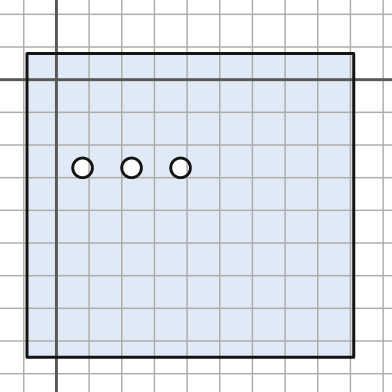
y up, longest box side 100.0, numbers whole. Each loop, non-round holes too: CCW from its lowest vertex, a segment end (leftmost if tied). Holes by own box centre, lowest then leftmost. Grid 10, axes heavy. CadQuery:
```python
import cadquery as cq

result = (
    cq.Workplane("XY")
    .moveTo(-9.0, -85.0)
    .lineTo(91.0, -85.0)
    .lineTo(91.0, 8.0)
    .lineTo(-9.0, 8.0)
    .close()
    .moveTo(8.0, -27.0)
    .circle(3.0)
    .moveTo(23.0, -27.0)
    .circle(3.0)
    .moveTo(38.0, -27.0)
    .circle(3.0)
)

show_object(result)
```